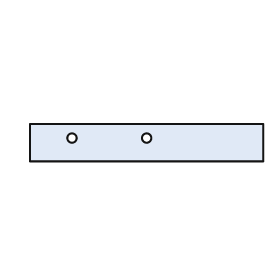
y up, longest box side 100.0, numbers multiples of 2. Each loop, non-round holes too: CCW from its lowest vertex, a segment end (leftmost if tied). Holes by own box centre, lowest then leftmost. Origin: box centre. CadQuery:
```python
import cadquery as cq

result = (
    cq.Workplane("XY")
    .moveTo(-50.0, -8.0)
    .lineTo(50.0, -8.0)
    .lineTo(50.0, 8.0)
    .lineTo(-50.0, 8.0)
    .close()
    .moveTo(-32.0, 2.0)
    .circle(2.0)
    .moveTo(0.0, 2.0)
    .circle(2.0)
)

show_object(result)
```